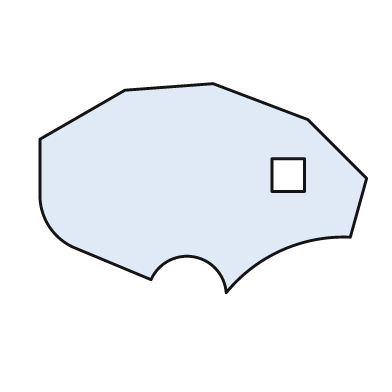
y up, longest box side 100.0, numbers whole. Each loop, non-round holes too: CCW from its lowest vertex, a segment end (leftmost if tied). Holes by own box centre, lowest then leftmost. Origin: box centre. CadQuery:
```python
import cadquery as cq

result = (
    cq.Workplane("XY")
    .moveTo(7.0, -32.0)
    .threePointArc((24.0, -19.0), (45.0, -15.0))
    .lineTo(50.0, 3.0)
    .lineTo(32.0, 21.0)
    .lineTo(3.0, 32.0)
    .lineTo(-24.0, 30.0)
    .lineTo(-50.0, 15.0)
    .lineTo(-50.0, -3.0)
    .threePointArc((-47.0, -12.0), (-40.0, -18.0))
    .lineTo(-16.0, -28.0)
    .threePointArc((-3.0, -21.0), (7.0, -32.0))
    .close()
    .moveTo(21.0, -1.0)
    .lineTo(31.0, -1.0)
    .lineTo(31.0, 9.0)
    .lineTo(21.0, 9.0)
    .close()
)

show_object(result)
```